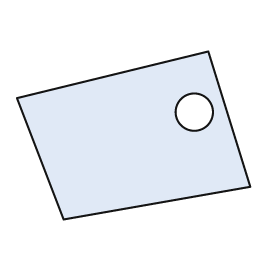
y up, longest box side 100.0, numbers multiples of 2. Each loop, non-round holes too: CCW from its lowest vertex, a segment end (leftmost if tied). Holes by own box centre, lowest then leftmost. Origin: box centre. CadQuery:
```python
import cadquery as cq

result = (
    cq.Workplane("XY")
    .moveTo(-30.0, -36.0)
    .lineTo(50.0, -22.0)
    .lineTo(32.0, 36.0)
    .lineTo(-50.0, 16.0)
    .close()
    .moveTo(26.0, 10.0)
    .circle(8.0)
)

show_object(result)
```